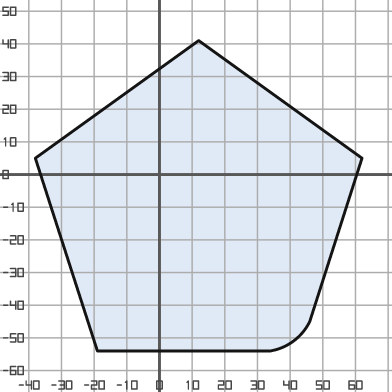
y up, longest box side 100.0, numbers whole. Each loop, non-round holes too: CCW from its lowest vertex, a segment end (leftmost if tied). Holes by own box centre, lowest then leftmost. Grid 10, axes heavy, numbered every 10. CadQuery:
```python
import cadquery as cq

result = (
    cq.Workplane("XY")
    .moveTo(-19.0, -54.0)
    .lineTo(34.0, -54.0)
    .threePointArc((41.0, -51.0), (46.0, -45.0))
    .lineTo(62.0, 5.0)
    .lineTo(12.0, 41.0)
    .lineTo(-38.0, 5.0)
    .close()
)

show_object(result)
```